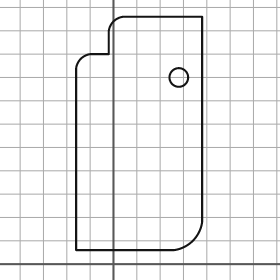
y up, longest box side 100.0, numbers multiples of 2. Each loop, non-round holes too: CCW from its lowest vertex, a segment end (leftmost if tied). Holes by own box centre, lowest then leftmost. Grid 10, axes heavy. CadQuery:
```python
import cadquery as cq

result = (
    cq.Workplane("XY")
    .moveTo(-16.0, 6.0)
    .lineTo(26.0, 6.0)
    .threePointArc((34.0, 10.0), (38.0, 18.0))
    .lineTo(38.0, 106.0)
    .lineTo(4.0, 106.0)
    .threePointArc((0.0, 104.0), (-2.0, 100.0))
    .lineTo(-2.0, 90.0)
    .lineTo(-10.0, 90.0)
    .threePointArc((-14.0, 88.0), (-16.0, 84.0))
    .close()
    .moveTo(28.0, 80.0)
    .circle(4.0)
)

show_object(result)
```